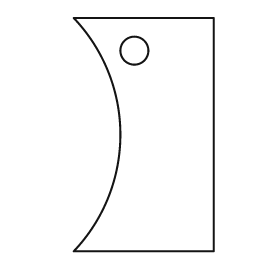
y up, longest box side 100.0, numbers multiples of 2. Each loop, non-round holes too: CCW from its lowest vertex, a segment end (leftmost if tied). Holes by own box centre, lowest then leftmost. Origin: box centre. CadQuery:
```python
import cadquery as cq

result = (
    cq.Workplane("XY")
    .moveTo(-30.0, -50.0)
    .lineTo(30.0, -50.0)
    .lineTo(30.0, 50.0)
    .lineTo(-30.0, 50.0)
    .threePointArc((-10.0, 0.0), (-30.0, -50.0))
    .close()
    .moveTo(-4.0, 36.0)
    .circle(6.0)
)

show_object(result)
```